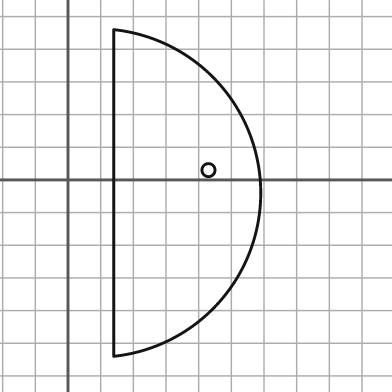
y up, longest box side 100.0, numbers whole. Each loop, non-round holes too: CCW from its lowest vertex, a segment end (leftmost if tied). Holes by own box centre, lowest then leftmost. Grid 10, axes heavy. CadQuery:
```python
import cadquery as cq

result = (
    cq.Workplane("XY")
    .moveTo(14.0, -54.0)
    .threePointArc((59.0, -4.0), (14.0, 46.0))
    .close()
    .moveTo(43.0, 3.0)
    .circle(2.0)
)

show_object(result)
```